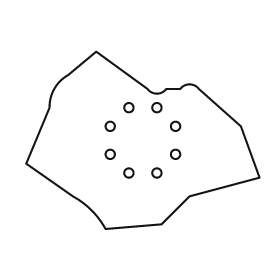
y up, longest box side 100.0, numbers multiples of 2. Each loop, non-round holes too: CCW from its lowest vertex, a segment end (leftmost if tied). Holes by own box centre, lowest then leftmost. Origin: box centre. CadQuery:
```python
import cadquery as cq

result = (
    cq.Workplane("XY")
    .moveTo(-16.0, -38.0)
    .lineTo(8.0, -36.0)
    .lineTo(20.0, -24.0)
    .lineTo(50.0, -16.0)
    .lineTo(42.0, 6.0)
    .lineTo(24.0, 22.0)
    .threePointArc((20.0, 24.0), (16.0, 22.0))
    .lineTo(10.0, 22.0)
    .threePointArc((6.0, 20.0), (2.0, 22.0))
    .lineTo(-20.0, 38.0)
    .lineTo(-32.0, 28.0)
    .threePointArc((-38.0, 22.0), (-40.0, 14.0))
    .lineTo(-50.0, -10.0)
    .lineTo(-30.0, -24.0)
    .threePointArc((-22.0, -30.0), (-16.0, -38.0))
    .close()
    .moveTo(-6.0, -14.0)
    .circle(2.0)
    .moveTo(6.0, -14.0)
    .circle(2.0)
    .moveTo(-14.0, -6.0)
    .circle(2.0)
    .moveTo(14.0, -6.0)
    .circle(2.0)
    .moveTo(-14.0, 6.0)
    .circle(2.0)
    .moveTo(14.0, 6.0)
    .circle(2.0)
    .moveTo(-6.0, 14.0)
    .circle(2.0)
    .moveTo(6.0, 14.0)
    .circle(2.0)
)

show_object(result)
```